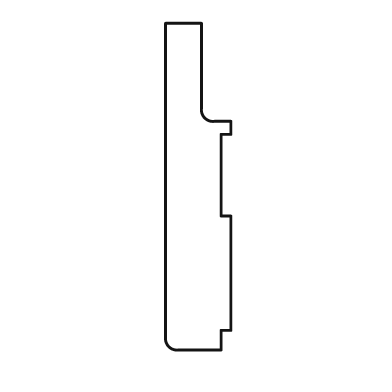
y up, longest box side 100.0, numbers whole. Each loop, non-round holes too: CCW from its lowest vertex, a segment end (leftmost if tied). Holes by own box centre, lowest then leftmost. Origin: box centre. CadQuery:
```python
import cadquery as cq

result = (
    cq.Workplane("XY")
    .moveTo(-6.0, -50.0)
    .lineTo(7.0, -50.0)
    .lineTo(7.0, -44.0)
    .lineTo(10.0, -44.0)
    .lineTo(10.0, -9.0)
    .lineTo(7.0, -9.0)
    .lineTo(7.0, 16.0)
    .lineTo(10.0, 16.0)
    .lineTo(10.0, 20.0)
    .lineTo(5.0, 20.0)
    .threePointArc((2.0, 21.0), (1.0, 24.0))
    .lineTo(1.0, 50.0)
    .lineTo(-10.0, 50.0)
    .lineTo(-10.0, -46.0)
    .threePointArc((-9.0, -49.0), (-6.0, -50.0))
    .close()
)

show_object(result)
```